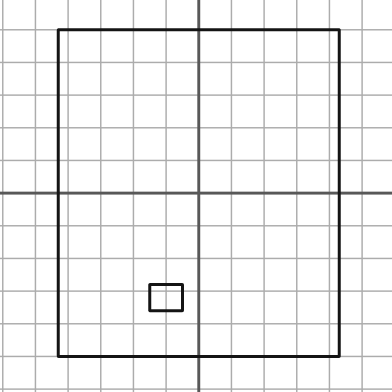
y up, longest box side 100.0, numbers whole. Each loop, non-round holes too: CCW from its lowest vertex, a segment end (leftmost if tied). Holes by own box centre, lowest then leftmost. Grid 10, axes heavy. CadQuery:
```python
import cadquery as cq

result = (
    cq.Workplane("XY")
    .moveTo(-43.0, -50.0)
    .lineTo(43.0, -50.0)
    .lineTo(43.0, 50.0)
    .lineTo(-43.0, 50.0)
    .close()
    .moveTo(-15.0, -36.0)
    .lineTo(-5.0, -36.0)
    .lineTo(-5.0, -28.0)
    .lineTo(-15.0, -28.0)
    .close()
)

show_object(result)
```